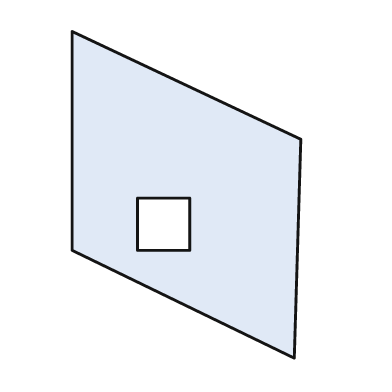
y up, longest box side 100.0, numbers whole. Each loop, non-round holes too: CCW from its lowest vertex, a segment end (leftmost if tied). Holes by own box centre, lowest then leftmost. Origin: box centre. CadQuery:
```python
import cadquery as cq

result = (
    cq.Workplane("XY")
    .moveTo(33.0, -50.0)
    .lineTo(35.0, 17.0)
    .lineTo(-35.0, 50.0)
    .lineTo(-35.0, -17.0)
    .close()
    .moveTo(-15.0, -17.0)
    .lineTo(1.0, -17.0)
    .lineTo(1.0, -1.0)
    .lineTo(-15.0, -1.0)
    .close()
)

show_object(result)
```